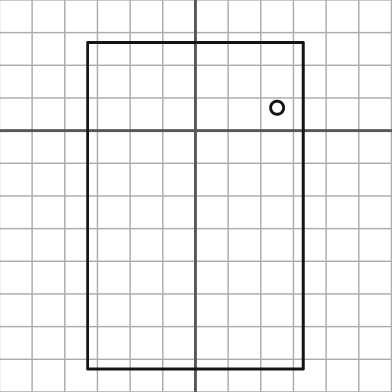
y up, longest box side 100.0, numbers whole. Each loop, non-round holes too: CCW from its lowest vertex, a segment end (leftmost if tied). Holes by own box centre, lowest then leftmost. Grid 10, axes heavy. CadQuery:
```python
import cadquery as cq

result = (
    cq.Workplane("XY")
    .moveTo(-33.0, -73.0)
    .lineTo(33.0, -73.0)
    .lineTo(33.0, 27.0)
    .lineTo(-33.0, 27.0)
    .close()
    .moveTo(25.0, 7.0)
    .circle(2.0)
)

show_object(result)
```